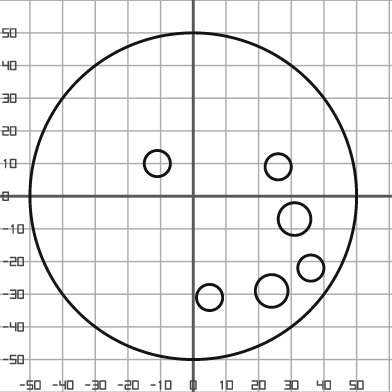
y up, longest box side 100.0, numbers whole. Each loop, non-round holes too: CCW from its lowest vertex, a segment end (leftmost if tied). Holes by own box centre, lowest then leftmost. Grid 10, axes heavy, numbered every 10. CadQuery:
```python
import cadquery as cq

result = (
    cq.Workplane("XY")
    .moveTo(0.0, 0.0)
    .circle(50.0)
    .moveTo(5.0, -31.0)
    .circle(4.0)
    .moveTo(24.0, -29.0)
    .circle(5.0)
    .moveTo(36.0, -22.0)
    .circle(4.0)
    .moveTo(31.0, -7.0)
    .circle(5.0)
    .moveTo(26.0, 9.0)
    .circle(4.0)
    .moveTo(-11.0, 10.0)
    .circle(4.0)
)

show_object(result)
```